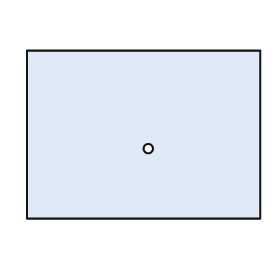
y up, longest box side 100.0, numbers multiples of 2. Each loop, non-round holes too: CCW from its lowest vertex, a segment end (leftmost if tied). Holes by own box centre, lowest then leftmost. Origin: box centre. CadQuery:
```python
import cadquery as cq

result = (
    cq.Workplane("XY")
    .moveTo(-50.0, -36.0)
    .lineTo(50.0, -36.0)
    .lineTo(50.0, 36.0)
    .lineTo(-50.0, 36.0)
    .close()
    .moveTo(2.0, -6.0)
    .circle(2.0)
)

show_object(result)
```